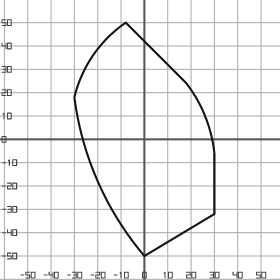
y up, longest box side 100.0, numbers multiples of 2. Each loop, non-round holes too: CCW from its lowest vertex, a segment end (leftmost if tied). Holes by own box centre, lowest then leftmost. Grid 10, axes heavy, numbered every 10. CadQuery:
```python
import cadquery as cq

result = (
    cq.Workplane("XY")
    .moveTo(0.0, -50.0)
    .lineTo(30.0, -32.0)
    .lineTo(30.0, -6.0)
    .threePointArc((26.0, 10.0), (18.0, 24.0))
    .lineTo(-8.0, 50.0)
    .threePointArc((-22.0, 36.0), (-30.0, 18.0))
    .threePointArc((-20.0, -18.0), (0.0, -50.0))
    .close()
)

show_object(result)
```